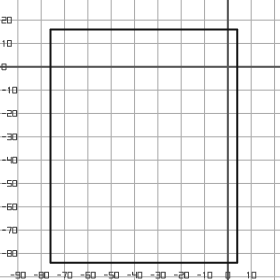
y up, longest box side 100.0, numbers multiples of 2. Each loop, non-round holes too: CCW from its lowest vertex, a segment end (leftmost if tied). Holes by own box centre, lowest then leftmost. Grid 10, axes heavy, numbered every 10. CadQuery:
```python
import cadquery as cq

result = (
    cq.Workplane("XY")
    .moveTo(-76.0, -84.0)
    .lineTo(4.0, -84.0)
    .lineTo(4.0, 16.0)
    .lineTo(-76.0, 16.0)
    .close()
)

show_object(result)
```